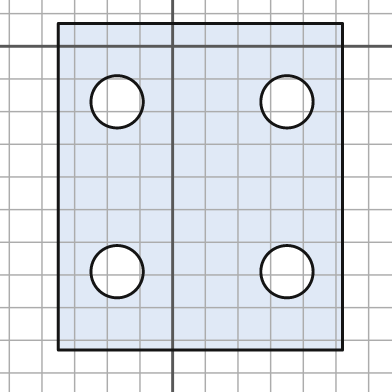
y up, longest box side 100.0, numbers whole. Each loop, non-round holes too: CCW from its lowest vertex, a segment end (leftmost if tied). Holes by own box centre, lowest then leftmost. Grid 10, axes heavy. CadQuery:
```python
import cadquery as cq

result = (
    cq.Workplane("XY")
    .moveTo(-35.0, -93.0)
    .lineTo(52.0, -93.0)
    .lineTo(52.0, 7.0)
    .lineTo(-35.0, 7.0)
    .close()
    .moveTo(-17.0, -69.0)
    .circle(8.0)
    .moveTo(35.0, -69.0)
    .circle(8.0)
    .moveTo(-17.0, -17.0)
    .circle(8.0)
    .moveTo(35.0, -17.0)
    .circle(8.0)
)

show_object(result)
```